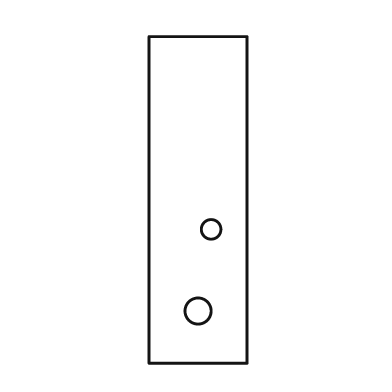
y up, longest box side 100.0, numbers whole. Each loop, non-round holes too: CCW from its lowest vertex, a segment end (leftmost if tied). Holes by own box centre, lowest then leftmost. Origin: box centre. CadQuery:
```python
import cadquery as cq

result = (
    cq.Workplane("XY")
    .moveTo(-15.0, -50.0)
    .lineTo(15.0, -50.0)
    .lineTo(15.0, 50.0)
    .lineTo(-15.0, 50.0)
    .close()
    .moveTo(0.0, -34.0)
    .circle(4.0)
    .moveTo(4.0, -9.0)
    .circle(3.0)
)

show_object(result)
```